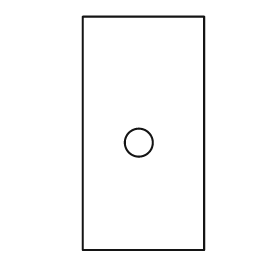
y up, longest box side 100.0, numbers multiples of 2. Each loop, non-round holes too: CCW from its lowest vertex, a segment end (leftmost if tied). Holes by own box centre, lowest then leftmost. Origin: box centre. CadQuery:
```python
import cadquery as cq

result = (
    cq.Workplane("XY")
    .moveTo(-26.0, -50.0)
    .lineTo(26.0, -50.0)
    .lineTo(26.0, 50.0)
    .lineTo(-26.0, 50.0)
    .close()
    .moveTo(-2.0, -4.0)
    .circle(6.0)
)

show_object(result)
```